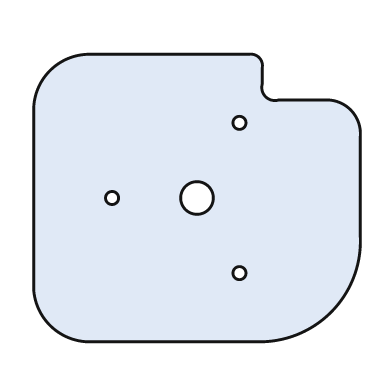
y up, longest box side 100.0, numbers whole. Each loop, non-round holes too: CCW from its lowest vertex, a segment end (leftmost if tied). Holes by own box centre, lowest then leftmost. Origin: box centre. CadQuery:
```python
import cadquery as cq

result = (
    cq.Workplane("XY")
    .moveTo(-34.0, -44.0)
    .lineTo(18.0, -44.0)
    .threePointArc((41.0, -35.0), (50.0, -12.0))
    .lineTo(50.0, 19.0)
    .threePointArc((47.0, 27.0), (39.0, 30.0))
    .lineTo(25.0, 30.0)
    .threePointArc((21.0, 31.0), (20.0, 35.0))
    .lineTo(20.0, 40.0)
    .threePointArc((19.0, 43.0), (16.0, 44.0))
    .lineTo(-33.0, 44.0)
    .threePointArc((-45.0, 39.0), (-50.0, 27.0))
    .lineTo(-50.0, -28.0)
    .threePointArc((-45.0, -39.0), (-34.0, -44.0))
    .close()
    .moveTo(13.0, -23.0)
    .circle(2.0)
    .moveTo(-26.0, 0.0)
    .circle(2.0)
    .moveTo(0.0, 0.0)
    .circle(5.0)
    .moveTo(13.0, 23.0)
    .circle(2.0)
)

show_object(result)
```